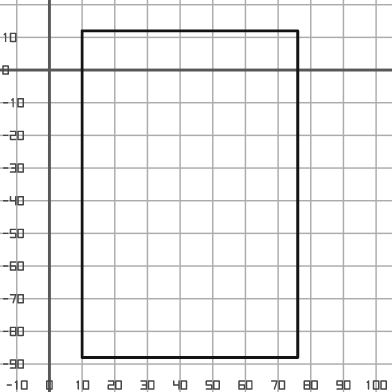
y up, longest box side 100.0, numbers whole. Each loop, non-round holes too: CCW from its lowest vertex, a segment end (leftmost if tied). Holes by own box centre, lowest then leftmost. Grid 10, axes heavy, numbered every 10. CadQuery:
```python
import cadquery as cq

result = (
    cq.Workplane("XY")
    .moveTo(10.0, -88.0)
    .lineTo(76.0, -88.0)
    .lineTo(76.0, 12.0)
    .lineTo(10.0, 12.0)
    .close()
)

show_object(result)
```